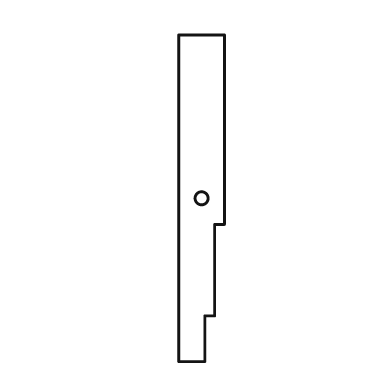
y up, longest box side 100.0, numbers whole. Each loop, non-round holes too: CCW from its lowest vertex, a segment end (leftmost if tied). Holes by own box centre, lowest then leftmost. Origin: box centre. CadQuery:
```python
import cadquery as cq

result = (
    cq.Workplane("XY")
    .moveTo(-7.0, -50.0)
    .lineTo(1.0, -50.0)
    .lineTo(1.0, -36.0)
    .lineTo(4.0, -36.0)
    .lineTo(4.0, -8.0)
    .lineTo(7.0, -8.0)
    .lineTo(7.0, 50.0)
    .lineTo(-7.0, 50.0)
    .close()
    .moveTo(0.0, 0.0)
    .circle(2.0)
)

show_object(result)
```